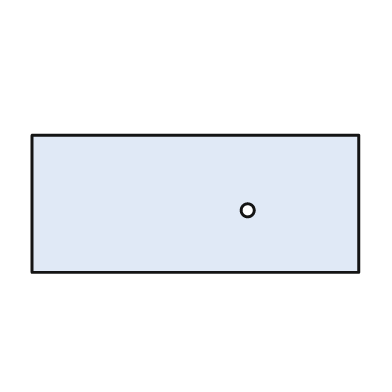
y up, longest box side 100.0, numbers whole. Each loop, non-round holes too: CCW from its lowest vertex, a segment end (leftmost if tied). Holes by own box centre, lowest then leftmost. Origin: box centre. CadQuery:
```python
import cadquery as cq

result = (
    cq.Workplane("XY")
    .moveTo(-50.0, -21.0)
    .lineTo(50.0, -21.0)
    .lineTo(50.0, 21.0)
    .lineTo(-50.0, 21.0)
    .close()
    .moveTo(16.0, -2.0)
    .circle(2.0)
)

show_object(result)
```